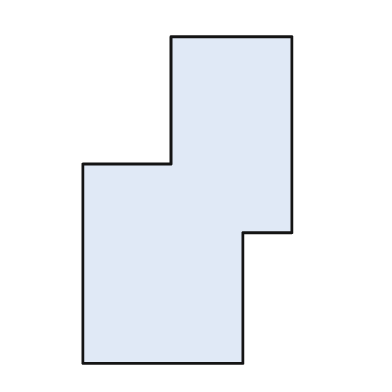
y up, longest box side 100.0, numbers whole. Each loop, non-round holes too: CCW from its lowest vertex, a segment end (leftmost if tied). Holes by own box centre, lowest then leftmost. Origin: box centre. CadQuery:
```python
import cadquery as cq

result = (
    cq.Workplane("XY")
    .moveTo(-32.0, -50.0)
    .lineTo(17.0, -50.0)
    .lineTo(17.0, -10.0)
    .lineTo(32.0, -10.0)
    .lineTo(32.0, 50.0)
    .lineTo(-5.0, 50.0)
    .lineTo(-5.0, 11.0)
    .lineTo(-32.0, 11.0)
    .close()
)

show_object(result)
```